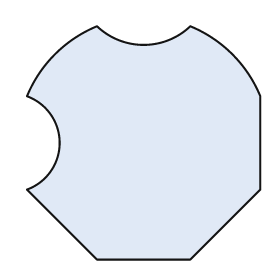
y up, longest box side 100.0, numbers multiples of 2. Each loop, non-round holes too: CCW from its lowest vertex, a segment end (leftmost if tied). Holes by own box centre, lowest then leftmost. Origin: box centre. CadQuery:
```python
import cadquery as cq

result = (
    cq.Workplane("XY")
    .moveTo(-20.0, -50.0)
    .lineTo(20.0, -50.0)
    .lineTo(50.0, -20.0)
    .lineTo(50.0, 20.0)
    .threePointArc((38.0, 38.0), (20.0, 50.0))
    .threePointArc((0.0, 42.0), (-20.0, 50.0))
    .threePointArc((-38.0, 38.0), (-50.0, 20.0))
    .threePointArc((-36.0, 0.0), (-50.0, -20.0))
    .close()
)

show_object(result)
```